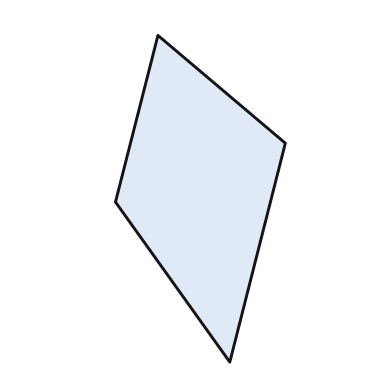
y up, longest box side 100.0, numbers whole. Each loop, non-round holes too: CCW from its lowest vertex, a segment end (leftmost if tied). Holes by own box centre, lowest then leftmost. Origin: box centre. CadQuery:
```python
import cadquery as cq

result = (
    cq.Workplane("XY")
    .moveTo(9.0, -50.0)
    .lineTo(26.0, 17.0)
    .lineTo(-13.0, 50.0)
    .lineTo(-26.0, -1.0)
    .close()
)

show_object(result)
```